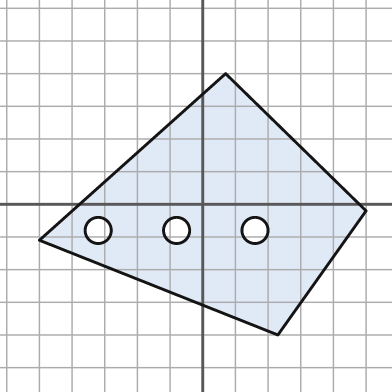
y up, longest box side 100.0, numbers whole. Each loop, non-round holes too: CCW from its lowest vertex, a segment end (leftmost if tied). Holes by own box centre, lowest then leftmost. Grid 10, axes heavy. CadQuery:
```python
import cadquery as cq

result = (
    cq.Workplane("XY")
    .moveTo(23.0, -40.0)
    .lineTo(50.0, -2.0)
    .lineTo(7.0, 40.0)
    .lineTo(-50.0, -11.0)
    .close()
    .moveTo(-32.0, -8.0)
    .circle(4.0)
    .moveTo(-8.0, -8.0)
    .circle(4.0)
    .moveTo(16.0, -8.0)
    .circle(4.0)
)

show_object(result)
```